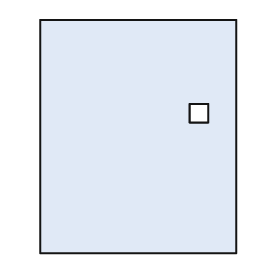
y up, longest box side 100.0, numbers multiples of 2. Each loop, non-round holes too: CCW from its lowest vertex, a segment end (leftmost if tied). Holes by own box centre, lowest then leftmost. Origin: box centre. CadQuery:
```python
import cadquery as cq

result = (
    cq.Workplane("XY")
    .moveTo(-42.0, -50.0)
    .lineTo(42.0, -50.0)
    .lineTo(42.0, 50.0)
    .lineTo(-42.0, 50.0)
    .close()
    .moveTo(22.0, 6.0)
    .lineTo(30.0, 6.0)
    .lineTo(30.0, 14.0)
    .lineTo(22.0, 14.0)
    .close()
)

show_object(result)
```